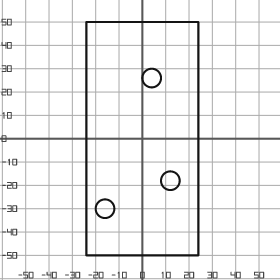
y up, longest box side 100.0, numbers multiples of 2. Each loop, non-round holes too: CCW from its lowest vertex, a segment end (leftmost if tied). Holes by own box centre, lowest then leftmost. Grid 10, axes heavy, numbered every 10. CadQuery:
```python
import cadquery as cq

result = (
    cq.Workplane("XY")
    .moveTo(-24.0, -50.0)
    .lineTo(24.0, -50.0)
    .lineTo(24.0, 50.0)
    .lineTo(-24.0, 50.0)
    .close()
    .moveTo(-16.0, -30.0)
    .circle(4.0)
    .moveTo(12.0, -18.0)
    .circle(4.0)
    .moveTo(4.0, 26.0)
    .circle(4.0)
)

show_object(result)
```